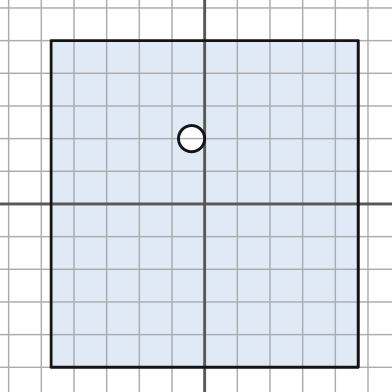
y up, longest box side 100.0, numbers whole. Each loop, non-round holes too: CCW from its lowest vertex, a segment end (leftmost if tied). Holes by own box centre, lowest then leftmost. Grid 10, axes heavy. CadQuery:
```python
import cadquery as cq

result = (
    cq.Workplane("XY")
    .moveTo(-47.0, -50.0)
    .lineTo(47.0, -50.0)
    .lineTo(47.0, 50.0)
    .lineTo(-47.0, 50.0)
    .close()
    .moveTo(-4.0, 20.0)
    .circle(4.0)
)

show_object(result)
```